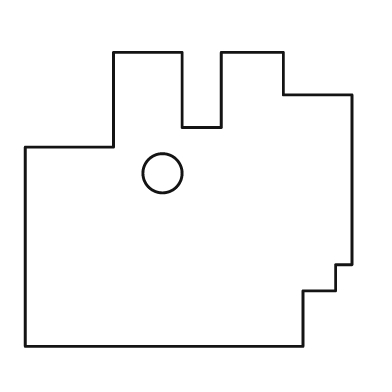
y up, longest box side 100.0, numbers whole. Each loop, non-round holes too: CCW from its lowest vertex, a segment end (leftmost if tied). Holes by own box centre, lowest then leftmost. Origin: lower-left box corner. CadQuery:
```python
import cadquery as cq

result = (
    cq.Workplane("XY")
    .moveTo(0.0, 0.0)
    .lineTo(85.0, 0.0)
    .lineTo(85.0, 17.0)
    .lineTo(95.0, 17.0)
    .lineTo(95.0, 25.0)
    .lineTo(100.0, 25.0)
    .lineTo(100.0, 77.0)
    .lineTo(79.0, 77.0)
    .lineTo(79.0, 90.0)
    .lineTo(60.0, 90.0)
    .lineTo(60.0, 67.0)
    .lineTo(48.0, 67.0)
    .lineTo(48.0, 90.0)
    .lineTo(27.0, 90.0)
    .lineTo(27.0, 61.0)
    .lineTo(0.0, 61.0)
    .close()
    .moveTo(42.0, 53.0)
    .circle(6.0)
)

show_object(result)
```